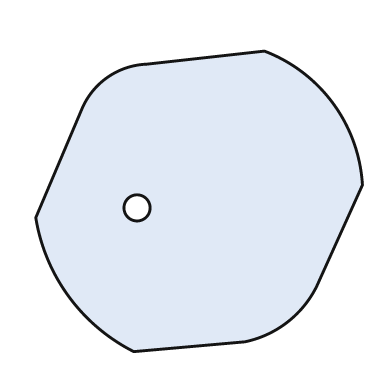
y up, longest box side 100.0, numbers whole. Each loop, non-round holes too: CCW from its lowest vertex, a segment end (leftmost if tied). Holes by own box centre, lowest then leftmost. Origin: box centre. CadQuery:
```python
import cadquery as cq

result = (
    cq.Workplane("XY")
    .moveTo(-20.0, -46.0)
    .lineTo(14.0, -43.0)
    .threePointArc((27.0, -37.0), (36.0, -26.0))
    .lineTo(50.0, 5.0)
    .threePointArc((41.0, 30.0), (20.0, 46.0))
    .lineTo(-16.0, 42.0)
    .threePointArc((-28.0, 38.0), (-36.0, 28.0))
    .lineTo(-50.0, -5.0)
    .threePointArc((-40.0, -29.0), (-20.0, -46.0))
    .close()
    .moveTo(-19.0, -2.0)
    .circle(4.0)
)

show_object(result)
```